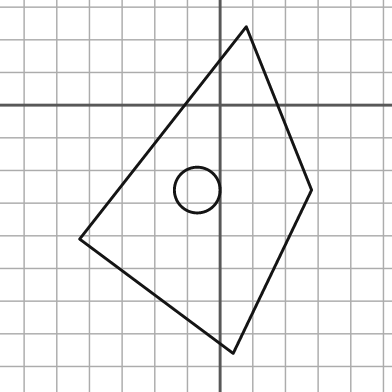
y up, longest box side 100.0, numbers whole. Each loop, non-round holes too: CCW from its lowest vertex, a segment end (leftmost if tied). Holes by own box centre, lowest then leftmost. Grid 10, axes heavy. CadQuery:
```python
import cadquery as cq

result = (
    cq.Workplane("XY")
    .moveTo(4.0, -76.0)
    .lineTo(28.0, -26.0)
    .lineTo(8.0, 24.0)
    .lineTo(-43.0, -41.0)
    .close()
    .moveTo(-7.0, -26.0)
    .circle(7.0)
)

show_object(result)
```